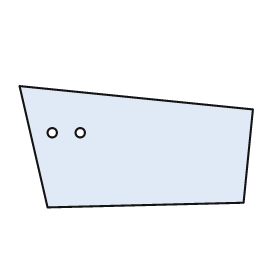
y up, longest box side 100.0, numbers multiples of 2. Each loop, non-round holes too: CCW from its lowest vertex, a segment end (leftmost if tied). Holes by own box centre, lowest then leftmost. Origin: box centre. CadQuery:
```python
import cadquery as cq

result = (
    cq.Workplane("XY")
    .moveTo(-38.0, -26.0)
    .lineTo(46.0, -24.0)
    .lineTo(50.0, 16.0)
    .lineTo(-50.0, 26.0)
    .close()
    .moveTo(-36.0, 6.0)
    .circle(2.0)
    .moveTo(-24.0, 6.0)
    .circle(2.0)
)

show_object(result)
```